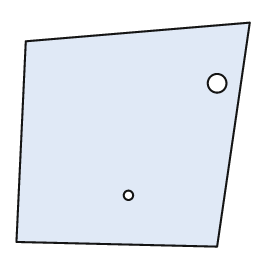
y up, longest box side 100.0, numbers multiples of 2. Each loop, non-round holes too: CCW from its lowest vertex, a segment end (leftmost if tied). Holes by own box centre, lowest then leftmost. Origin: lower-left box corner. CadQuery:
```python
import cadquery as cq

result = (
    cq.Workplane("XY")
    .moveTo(86.0, 0.0)
    .lineTo(100.0, 96.0)
    .lineTo(4.0, 88.0)
    .lineTo(0.0, 2.0)
    .close()
    .moveTo(48.0, 22.0)
    .circle(2.0)
    .moveTo(86.0, 70.0)
    .circle(4.0)
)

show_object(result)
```